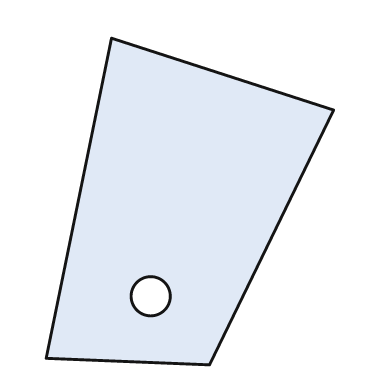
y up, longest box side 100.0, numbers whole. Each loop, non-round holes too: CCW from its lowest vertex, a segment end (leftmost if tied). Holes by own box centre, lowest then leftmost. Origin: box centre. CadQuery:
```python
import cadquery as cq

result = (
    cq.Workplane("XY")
    .moveTo(6.0, -50.0)
    .lineTo(44.0, 28.0)
    .lineTo(-24.0, 50.0)
    .lineTo(-44.0, -48.0)
    .close()
    .moveTo(-12.0, -29.0)
    .circle(6.0)
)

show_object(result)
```